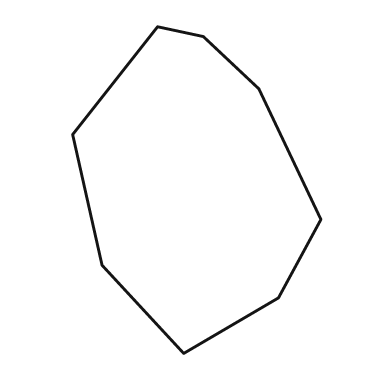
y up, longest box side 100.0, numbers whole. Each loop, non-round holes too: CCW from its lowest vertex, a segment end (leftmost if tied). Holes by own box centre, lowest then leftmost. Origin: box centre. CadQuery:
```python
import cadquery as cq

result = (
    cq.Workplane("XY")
    .moveTo(-4.0, -50.0)
    .lineTo(25.0, -33.0)
    .lineTo(38.0, -9.0)
    .lineTo(19.0, 31.0)
    .lineTo(2.0, 47.0)
    .lineTo(-12.0, 50.0)
    .lineTo(-38.0, 17.0)
    .lineTo(-29.0, -23.0)
    .close()
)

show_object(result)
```